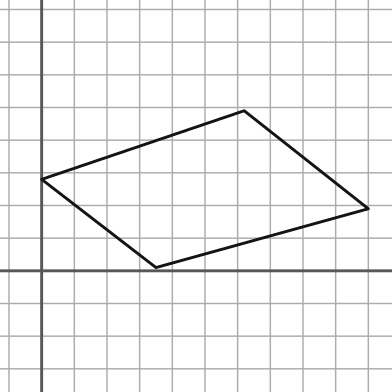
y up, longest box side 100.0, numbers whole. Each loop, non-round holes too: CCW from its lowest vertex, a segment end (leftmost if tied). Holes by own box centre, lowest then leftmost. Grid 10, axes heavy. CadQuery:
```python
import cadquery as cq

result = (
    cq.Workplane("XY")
    .moveTo(35.0, 1.0)
    .lineTo(100.0, 19.0)
    .lineTo(62.0, 49.0)
    .lineTo(0.0, 28.0)
    .close()
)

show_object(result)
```